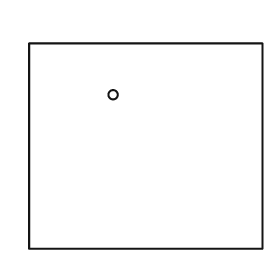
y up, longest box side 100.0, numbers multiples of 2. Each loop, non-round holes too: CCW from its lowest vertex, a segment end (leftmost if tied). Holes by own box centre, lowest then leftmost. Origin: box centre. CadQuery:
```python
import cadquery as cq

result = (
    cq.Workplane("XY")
    .moveTo(-50.0, -44.0)
    .lineTo(50.0, -44.0)
    .lineTo(50.0, 44.0)
    .lineTo(-50.0, 44.0)
    .close()
    .moveTo(-14.0, 22.0)
    .circle(2.0)
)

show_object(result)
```